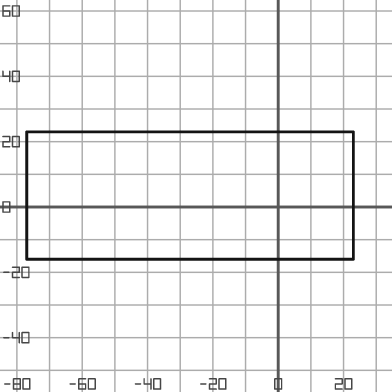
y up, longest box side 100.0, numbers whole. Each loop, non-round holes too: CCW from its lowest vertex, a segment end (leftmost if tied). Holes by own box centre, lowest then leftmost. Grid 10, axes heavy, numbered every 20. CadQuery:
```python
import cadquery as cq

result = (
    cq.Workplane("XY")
    .moveTo(-77.0, -16.0)
    .lineTo(23.0, -16.0)
    .lineTo(23.0, 23.0)
    .lineTo(-77.0, 23.0)
    .close()
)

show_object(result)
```